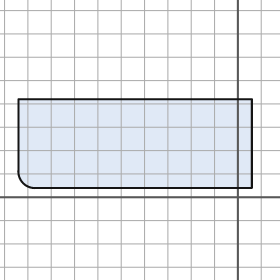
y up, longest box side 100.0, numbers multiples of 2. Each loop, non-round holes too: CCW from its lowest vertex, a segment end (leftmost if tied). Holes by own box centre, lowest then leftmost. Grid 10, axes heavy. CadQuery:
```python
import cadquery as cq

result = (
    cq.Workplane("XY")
    .moveTo(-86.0, 4.0)
    .lineTo(6.0, 4.0)
    .lineTo(6.0, 42.0)
    .lineTo(-94.0, 42.0)
    .lineTo(-94.0, 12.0)
    .threePointArc((-92.0, 6.0), (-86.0, 4.0))
    .close()
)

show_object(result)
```